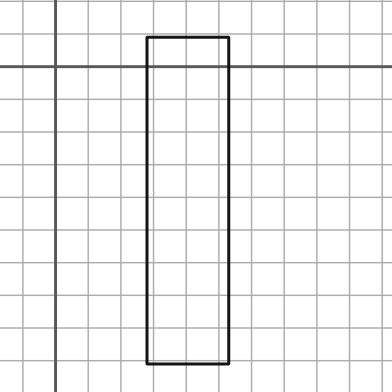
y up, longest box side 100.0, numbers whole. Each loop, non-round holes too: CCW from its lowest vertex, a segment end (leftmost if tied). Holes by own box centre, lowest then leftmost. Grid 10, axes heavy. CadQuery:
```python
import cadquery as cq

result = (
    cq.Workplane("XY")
    .moveTo(28.0, -91.0)
    .lineTo(53.0, -91.0)
    .lineTo(53.0, 9.0)
    .lineTo(28.0, 9.0)
    .close()
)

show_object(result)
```